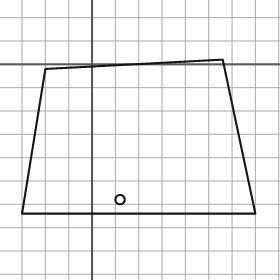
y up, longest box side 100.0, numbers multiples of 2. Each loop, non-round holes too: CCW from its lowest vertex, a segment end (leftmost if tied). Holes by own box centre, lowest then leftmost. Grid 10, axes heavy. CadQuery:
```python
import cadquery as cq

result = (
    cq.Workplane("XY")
    .moveTo(-30.0, -64.0)
    .lineTo(70.0, -64.0)
    .lineTo(56.0, 2.0)
    .lineTo(-20.0, -2.0)
    .close()
    .moveTo(12.0, -58.0)
    .circle(2.0)
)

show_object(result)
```